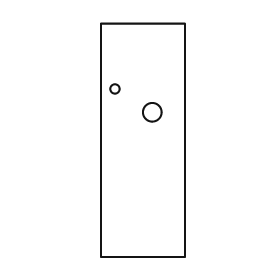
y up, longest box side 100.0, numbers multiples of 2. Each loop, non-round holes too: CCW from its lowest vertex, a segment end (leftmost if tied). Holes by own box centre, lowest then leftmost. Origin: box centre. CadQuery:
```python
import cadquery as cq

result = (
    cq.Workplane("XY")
    .moveTo(-18.0, -50.0)
    .lineTo(18.0, -50.0)
    .lineTo(18.0, 50.0)
    .lineTo(-18.0, 50.0)
    .close()
    .moveTo(4.0, 12.0)
    .circle(4.0)
    .moveTo(-12.0, 22.0)
    .circle(2.0)
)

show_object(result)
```